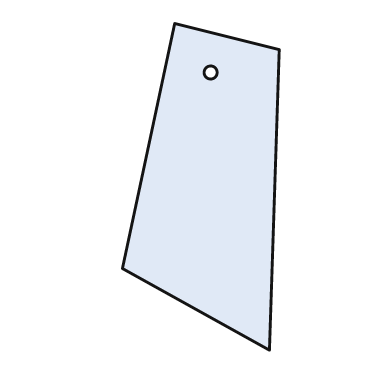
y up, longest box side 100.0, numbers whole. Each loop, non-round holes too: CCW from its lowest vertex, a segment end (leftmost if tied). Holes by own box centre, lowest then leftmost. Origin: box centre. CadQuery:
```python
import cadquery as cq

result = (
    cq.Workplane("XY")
    .moveTo(21.0, -50.0)
    .lineTo(24.0, 42.0)
    .lineTo(-8.0, 50.0)
    .lineTo(-24.0, -25.0)
    .close()
    .moveTo(3.0, 35.0)
    .circle(2.0)
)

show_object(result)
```